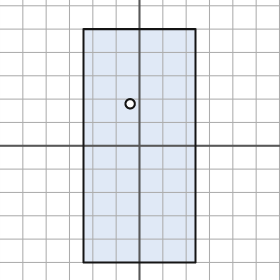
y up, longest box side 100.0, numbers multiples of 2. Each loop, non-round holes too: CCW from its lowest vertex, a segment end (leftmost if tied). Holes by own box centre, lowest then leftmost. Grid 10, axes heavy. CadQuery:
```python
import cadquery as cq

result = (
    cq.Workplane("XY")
    .moveTo(-24.0, -50.0)
    .lineTo(24.0, -50.0)
    .lineTo(24.0, 50.0)
    .lineTo(-24.0, 50.0)
    .close()
    .moveTo(-4.0, 18.0)
    .circle(2.0)
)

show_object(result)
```